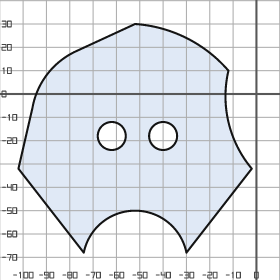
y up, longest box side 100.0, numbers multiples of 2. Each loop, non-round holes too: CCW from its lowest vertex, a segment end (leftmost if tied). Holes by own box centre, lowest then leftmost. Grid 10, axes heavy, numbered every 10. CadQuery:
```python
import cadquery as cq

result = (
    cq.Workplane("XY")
    .moveTo(-74.0, -68.0)
    .threePointArc((-52.0, -50.0), (-30.0, -68.0))
    .lineTo(-2.0, -32.0)
    .threePointArc((-12.0, -12.0), (-12.0, 10.0))
    .threePointArc((-30.0, 24.0), (-52.0, 30.0))
    .lineTo(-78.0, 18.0)
    .threePointArc((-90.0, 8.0), (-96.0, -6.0))
    .lineTo(-102.0, -32.0)
    .close()
    .moveTo(-62.0, -18.0)
    .circle(6.0)
    .moveTo(-40.0, -18.0)
    .circle(6.0)
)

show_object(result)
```